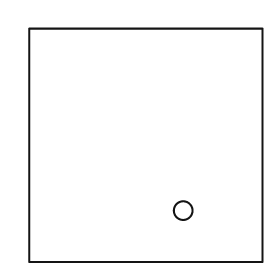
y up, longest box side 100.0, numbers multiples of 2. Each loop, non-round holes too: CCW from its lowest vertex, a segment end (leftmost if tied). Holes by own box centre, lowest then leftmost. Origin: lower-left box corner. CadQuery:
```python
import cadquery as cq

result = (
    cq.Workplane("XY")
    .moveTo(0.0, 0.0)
    .lineTo(100.0, 0.0)
    .lineTo(100.0, 100.0)
    .lineTo(0.0, 100.0)
    .close()
    .moveTo(66.0, 22.0)
    .circle(4.0)
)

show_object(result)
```